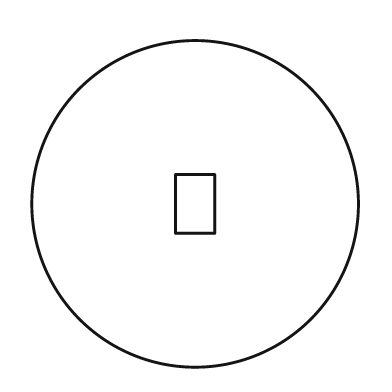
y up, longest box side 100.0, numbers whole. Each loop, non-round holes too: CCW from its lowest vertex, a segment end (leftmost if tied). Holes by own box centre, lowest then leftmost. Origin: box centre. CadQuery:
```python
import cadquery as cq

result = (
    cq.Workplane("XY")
    .moveTo(0.0, 0.0)
    .circle(50.0)
    .moveTo(-6.0, -9.0)
    .lineTo(6.0, -9.0)
    .lineTo(6.0, 9.0)
    .lineTo(-6.0, 9.0)
    .close()
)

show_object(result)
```